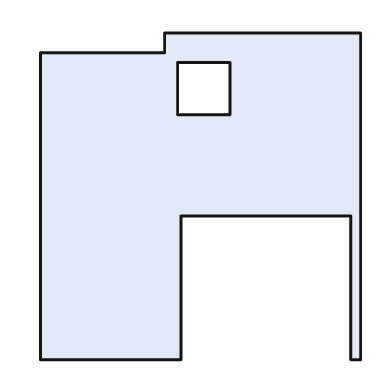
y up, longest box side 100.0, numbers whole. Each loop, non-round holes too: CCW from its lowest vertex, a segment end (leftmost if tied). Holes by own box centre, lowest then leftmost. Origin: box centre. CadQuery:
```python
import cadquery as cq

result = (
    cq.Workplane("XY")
    .moveTo(-49.0, -50.0)
    .lineTo(-6.0, -50.0)
    .lineTo(-6.0, -6.0)
    .lineTo(46.0, -6.0)
    .lineTo(46.0, -50.0)
    .lineTo(49.0, -50.0)
    .lineTo(49.0, 50.0)
    .lineTo(-11.0, 50.0)
    .lineTo(-11.0, 44.0)
    .lineTo(-49.0, 44.0)
    .close()
    .moveTo(-7.0, 25.0)
    .lineTo(9.0, 25.0)
    .lineTo(9.0, 41.0)
    .lineTo(-7.0, 41.0)
    .close()
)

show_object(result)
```